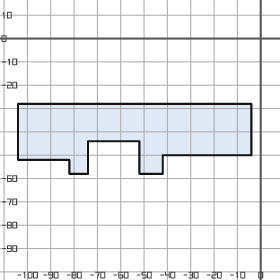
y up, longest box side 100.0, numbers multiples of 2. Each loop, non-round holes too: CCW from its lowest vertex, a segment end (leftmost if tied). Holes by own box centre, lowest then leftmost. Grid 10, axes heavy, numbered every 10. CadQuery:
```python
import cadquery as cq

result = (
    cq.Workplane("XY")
    .moveTo(-82.0, -58.0)
    .lineTo(-74.0, -58.0)
    .lineTo(-74.0, -44.0)
    .lineTo(-52.0, -44.0)
    .lineTo(-52.0, -58.0)
    .lineTo(-42.0, -58.0)
    .lineTo(-42.0, -50.0)
    .lineTo(-4.0, -50.0)
    .lineTo(-4.0, -28.0)
    .lineTo(-104.0, -28.0)
    .lineTo(-104.0, -52.0)
    .lineTo(-82.0, -52.0)
    .close()
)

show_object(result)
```